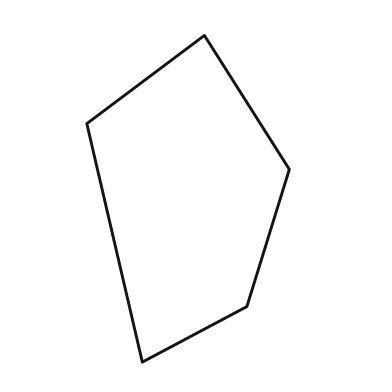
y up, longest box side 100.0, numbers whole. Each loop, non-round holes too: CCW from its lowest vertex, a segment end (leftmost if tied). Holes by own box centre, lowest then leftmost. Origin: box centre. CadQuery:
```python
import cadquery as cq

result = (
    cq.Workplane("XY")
    .moveTo(-14.0, -50.0)
    .lineTo(18.0, -33.0)
    .lineTo(31.0, 9.0)
    .lineTo(5.0, 50.0)
    .lineTo(-31.0, 23.0)
    .close()
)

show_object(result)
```